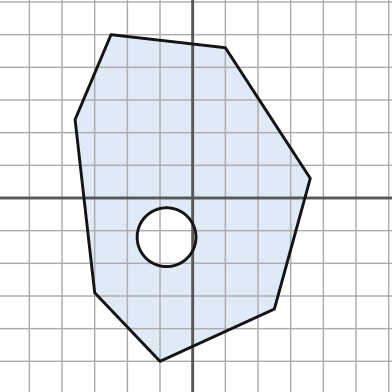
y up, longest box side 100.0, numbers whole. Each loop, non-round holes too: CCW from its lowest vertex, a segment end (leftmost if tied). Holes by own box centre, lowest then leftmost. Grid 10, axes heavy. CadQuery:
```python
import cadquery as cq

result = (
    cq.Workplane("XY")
    .moveTo(-10.0, -50.0)
    .lineTo(25.0, -34.0)
    .lineTo(36.0, 6.0)
    .lineTo(10.0, 46.0)
    .lineTo(-25.0, 50.0)
    .lineTo(-36.0, 24.0)
    .lineTo(-30.0, -29.0)
    .close()
    .moveTo(-8.0, -12.0)
    .circle(9.0)
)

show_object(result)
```